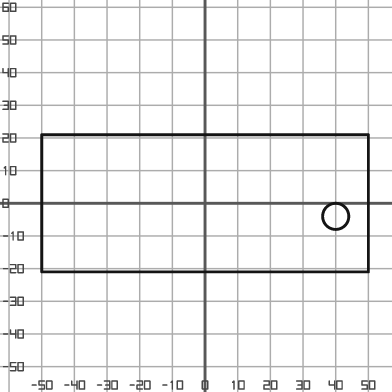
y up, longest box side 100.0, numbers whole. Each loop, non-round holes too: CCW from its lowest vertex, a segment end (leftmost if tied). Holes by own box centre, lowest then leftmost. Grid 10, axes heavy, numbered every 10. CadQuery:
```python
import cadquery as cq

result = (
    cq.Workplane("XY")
    .moveTo(-50.0, -21.0)
    .lineTo(50.0, -21.0)
    .lineTo(50.0, 21.0)
    .lineTo(-50.0, 21.0)
    .close()
    .moveTo(40.0, -4.0)
    .circle(4.0)
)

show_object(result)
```